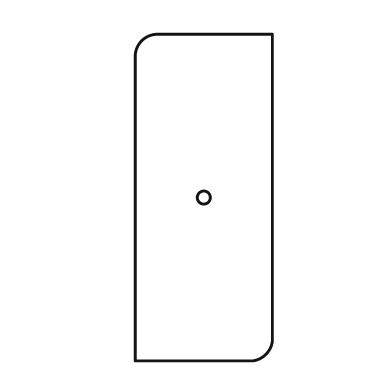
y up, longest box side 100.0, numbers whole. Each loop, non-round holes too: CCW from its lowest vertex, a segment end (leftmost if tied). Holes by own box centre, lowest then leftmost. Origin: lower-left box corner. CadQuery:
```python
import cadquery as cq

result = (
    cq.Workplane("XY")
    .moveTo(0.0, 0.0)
    .lineTo(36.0, 0.0)
    .threePointArc((40.0, 2.0), (42.0, 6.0))
    .lineTo(42.0, 100.0)
    .lineTo(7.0, 100.0)
    .threePointArc((2.0, 98.0), (0.0, 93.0))
    .close()
    .moveTo(21.0, 50.0)
    .circle(2.0)
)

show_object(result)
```